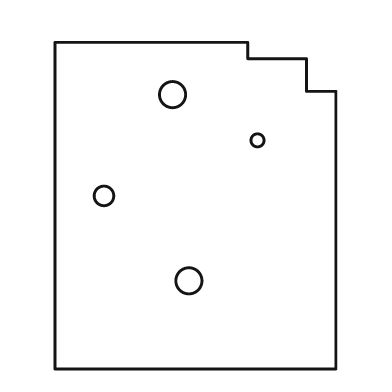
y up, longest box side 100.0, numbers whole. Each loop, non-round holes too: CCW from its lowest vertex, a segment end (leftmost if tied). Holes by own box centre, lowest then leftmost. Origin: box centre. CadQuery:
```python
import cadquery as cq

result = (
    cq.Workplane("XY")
    .moveTo(-43.0, -50.0)
    .lineTo(43.0, -50.0)
    .lineTo(43.0, 35.0)
    .lineTo(34.0, 35.0)
    .lineTo(34.0, 45.0)
    .lineTo(16.0, 45.0)
    .lineTo(16.0, 50.0)
    .lineTo(-43.0, 50.0)
    .close()
    .moveTo(-2.0, -23.0)
    .circle(4.0)
    .moveTo(-28.0, 3.0)
    .circle(3.0)
    .moveTo(19.0, 20.0)
    .circle(2.0)
    .moveTo(-7.0, 34.0)
    .circle(4.0)
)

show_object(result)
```